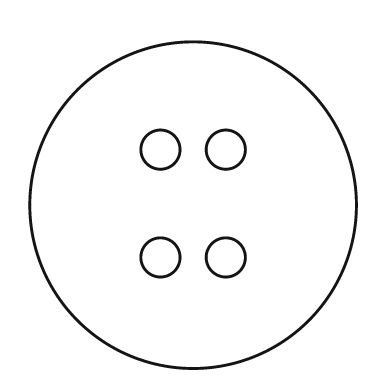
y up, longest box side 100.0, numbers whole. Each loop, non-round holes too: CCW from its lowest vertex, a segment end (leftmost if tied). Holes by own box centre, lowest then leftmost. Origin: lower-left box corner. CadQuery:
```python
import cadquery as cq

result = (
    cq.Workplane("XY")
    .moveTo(50.0, 50.0)
    .circle(50.0)
    .moveTo(40.0, 34.0)
    .circle(6.0)
    .moveTo(60.0, 34.0)
    .circle(6.0)
    .moveTo(40.0, 67.0)
    .circle(6.0)
    .moveTo(60.0, 67.0)
    .circle(6.0)
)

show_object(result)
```